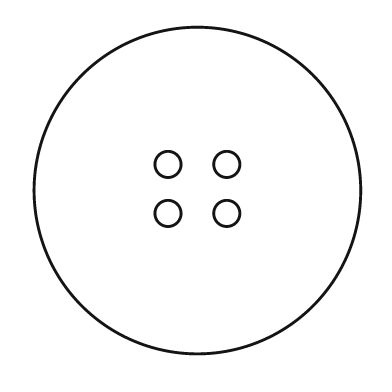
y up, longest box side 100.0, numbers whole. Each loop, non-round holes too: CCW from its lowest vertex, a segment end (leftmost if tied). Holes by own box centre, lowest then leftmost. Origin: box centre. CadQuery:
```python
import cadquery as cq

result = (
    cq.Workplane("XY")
    .moveTo(0.0, 0.0)
    .circle(50.0)
    .moveTo(-9.0, -7.0)
    .circle(4.0)
    .moveTo(9.0, -7.0)
    .circle(4.0)
    .moveTo(-9.0, 8.0)
    .circle(4.0)
    .moveTo(9.0, 8.0)
    .circle(4.0)
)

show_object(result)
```